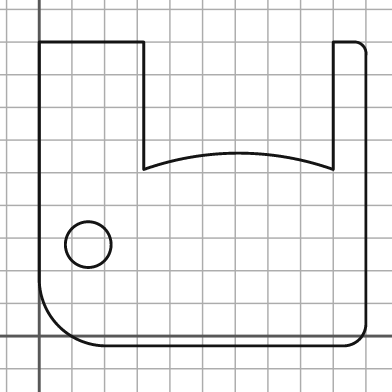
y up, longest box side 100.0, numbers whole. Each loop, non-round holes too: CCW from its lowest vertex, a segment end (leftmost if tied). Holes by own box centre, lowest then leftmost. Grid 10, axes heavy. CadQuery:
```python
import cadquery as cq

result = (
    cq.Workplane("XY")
    .moveTo(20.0, -3.0)
    .lineTo(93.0, -3.0)
    .threePointArc((98.0, -1.0), (100.0, 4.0))
    .lineTo(100.0, 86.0)
    .threePointArc((99.0, 89.0), (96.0, 90.0))
    .lineTo(90.0, 90.0)
    .lineTo(90.0, 51.0)
    .threePointArc((61.0, 56.0), (32.0, 51.0))
    .lineTo(32.0, 90.0)
    .lineTo(0.0, 90.0)
    .lineTo(0.0, 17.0)
    .threePointArc((6.0, 3.0), (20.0, -3.0))
    .close()
    .moveTo(15.0, 28.0)
    .circle(7.0)
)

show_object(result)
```